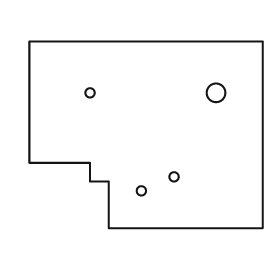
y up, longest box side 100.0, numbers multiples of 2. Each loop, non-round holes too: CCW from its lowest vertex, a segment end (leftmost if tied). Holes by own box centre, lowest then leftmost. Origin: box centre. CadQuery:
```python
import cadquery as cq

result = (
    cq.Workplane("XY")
    .moveTo(-16.0, -40.0)
    .lineTo(50.0, -40.0)
    .lineTo(50.0, 40.0)
    .lineTo(-50.0, 40.0)
    .lineTo(-50.0, -12.0)
    .lineTo(-24.0, -12.0)
    .lineTo(-24.0, -20.0)
    .lineTo(-16.0, -20.0)
    .close()
    .moveTo(-2.0, -24.0)
    .circle(2.0)
    .moveTo(12.0, -18.0)
    .circle(2.0)
    .moveTo(-24.0, 18.0)
    .circle(2.0)
    .moveTo(30.0, 18.0)
    .circle(4.0)
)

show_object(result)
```